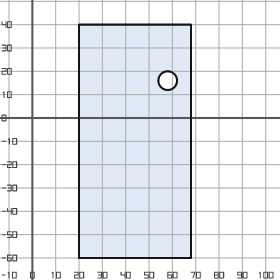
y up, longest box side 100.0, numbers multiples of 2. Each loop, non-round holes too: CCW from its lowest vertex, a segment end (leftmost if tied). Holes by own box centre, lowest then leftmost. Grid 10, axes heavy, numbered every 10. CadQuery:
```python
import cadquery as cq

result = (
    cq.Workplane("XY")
    .moveTo(20.0, -60.0)
    .lineTo(68.0, -60.0)
    .lineTo(68.0, 40.0)
    .lineTo(20.0, 40.0)
    .close()
    .moveTo(58.0, 16.0)
    .circle(4.0)
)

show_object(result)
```